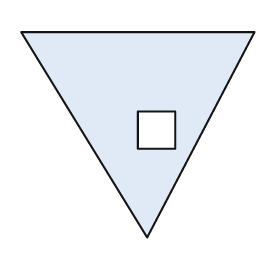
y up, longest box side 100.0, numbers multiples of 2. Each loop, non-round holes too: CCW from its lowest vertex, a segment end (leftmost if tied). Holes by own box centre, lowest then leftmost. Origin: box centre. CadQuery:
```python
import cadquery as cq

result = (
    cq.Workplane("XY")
    .moveTo(4.0, -44.0)
    .lineTo(50.0, 44.0)
    .lineTo(-50.0, 44.0)
    .close()
    .moveTo(0.0, -6.0)
    .lineTo(16.0, -6.0)
    .lineTo(16.0, 10.0)
    .lineTo(0.0, 10.0)
    .close()
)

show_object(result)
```